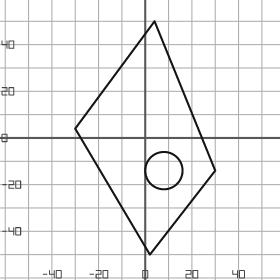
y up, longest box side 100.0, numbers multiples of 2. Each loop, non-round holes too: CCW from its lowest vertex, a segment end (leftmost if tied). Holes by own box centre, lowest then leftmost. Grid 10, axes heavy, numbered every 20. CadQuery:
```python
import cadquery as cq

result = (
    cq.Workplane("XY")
    .moveTo(2.0, -50.0)
    .lineTo(30.0, -14.0)
    .lineTo(4.0, 50.0)
    .lineTo(-30.0, 4.0)
    .close()
    .moveTo(8.0, -14.0)
    .circle(8.0)
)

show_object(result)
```